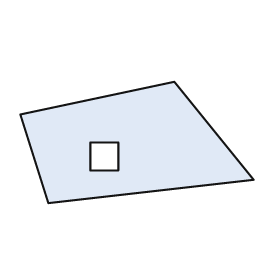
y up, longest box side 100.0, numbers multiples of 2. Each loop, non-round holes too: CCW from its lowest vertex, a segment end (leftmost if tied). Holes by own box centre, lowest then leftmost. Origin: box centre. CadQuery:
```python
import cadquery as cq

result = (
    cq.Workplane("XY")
    .moveTo(-38.0, -26.0)
    .lineTo(50.0, -16.0)
    .lineTo(16.0, 26.0)
    .lineTo(-50.0, 12.0)
    .close()
    .moveTo(-20.0, -12.0)
    .lineTo(-8.0, -12.0)
    .lineTo(-8.0, 0.0)
    .lineTo(-20.0, 0.0)
    .close()
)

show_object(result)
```